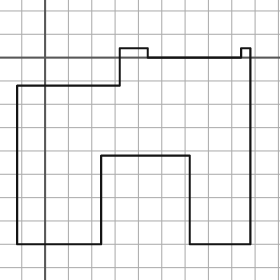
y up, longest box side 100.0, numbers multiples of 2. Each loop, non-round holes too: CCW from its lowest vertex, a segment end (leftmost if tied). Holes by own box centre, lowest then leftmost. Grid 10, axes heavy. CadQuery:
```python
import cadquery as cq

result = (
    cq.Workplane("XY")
    .moveTo(-12.0, -80.0)
    .lineTo(24.0, -80.0)
    .lineTo(24.0, -42.0)
    .lineTo(62.0, -42.0)
    .lineTo(62.0, -80.0)
    .lineTo(88.0, -80.0)
    .lineTo(88.0, 4.0)
    .lineTo(84.0, 4.0)
    .lineTo(84.0, 0.0)
    .lineTo(44.0, 0.0)
    .lineTo(44.0, 4.0)
    .lineTo(32.0, 4.0)
    .lineTo(32.0, -12.0)
    .lineTo(-12.0, -12.0)
    .close()
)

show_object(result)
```